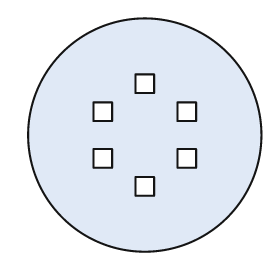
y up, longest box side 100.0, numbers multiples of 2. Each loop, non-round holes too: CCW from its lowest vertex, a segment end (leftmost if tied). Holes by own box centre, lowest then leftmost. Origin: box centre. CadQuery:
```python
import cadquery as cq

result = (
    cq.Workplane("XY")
    .moveTo(0.0, 0.0)
    .circle(50.0)
    .moveTo(-4.0, -26.0)
    .lineTo(4.0, -26.0)
    .lineTo(4.0, -18.0)
    .lineTo(-4.0, -18.0)
    .close()
    .moveTo(-22.0, -14.0)
    .lineTo(-14.0, -14.0)
    .lineTo(-14.0, -6.0)
    .lineTo(-22.0, -6.0)
    .close()
    .moveTo(14.0, -14.0)
    .lineTo(22.0, -14.0)
    .lineTo(22.0, -6.0)
    .lineTo(14.0, -6.0)
    .close()
    .moveTo(-22.0, 6.0)
    .lineTo(-14.0, 6.0)
    .lineTo(-14.0, 14.0)
    .lineTo(-22.0, 14.0)
    .close()
    .moveTo(14.0, 6.0)
    .lineTo(22.0, 6.0)
    .lineTo(22.0, 14.0)
    .lineTo(14.0, 14.0)
    .close()
    .moveTo(-4.0, 18.0)
    .lineTo(4.0, 18.0)
    .lineTo(4.0, 26.0)
    .lineTo(-4.0, 26.0)
    .close()
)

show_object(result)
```